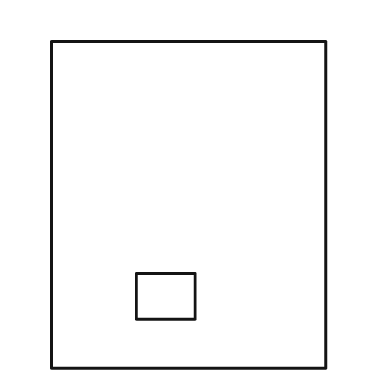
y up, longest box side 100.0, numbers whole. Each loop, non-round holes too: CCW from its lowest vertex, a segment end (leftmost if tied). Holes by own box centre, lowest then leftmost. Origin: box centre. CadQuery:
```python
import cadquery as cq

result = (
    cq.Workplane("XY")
    .moveTo(-42.0, -50.0)
    .lineTo(42.0, -50.0)
    .lineTo(42.0, 50.0)
    .lineTo(-42.0, 50.0)
    .close()
    .moveTo(-16.0, -35.0)
    .lineTo(2.0, -35.0)
    .lineTo(2.0, -21.0)
    .lineTo(-16.0, -21.0)
    .close()
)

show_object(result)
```